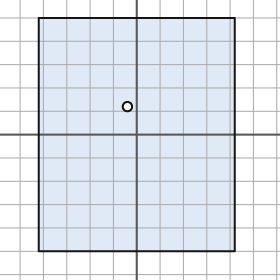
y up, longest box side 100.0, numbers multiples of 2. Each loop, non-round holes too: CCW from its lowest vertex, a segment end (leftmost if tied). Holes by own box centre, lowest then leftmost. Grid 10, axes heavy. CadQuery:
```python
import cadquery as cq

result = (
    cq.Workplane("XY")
    .moveTo(-42.0, -50.0)
    .lineTo(42.0, -50.0)
    .lineTo(42.0, 50.0)
    .lineTo(-42.0, 50.0)
    .close()
    .moveTo(-4.0, 12.0)
    .circle(2.0)
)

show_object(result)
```